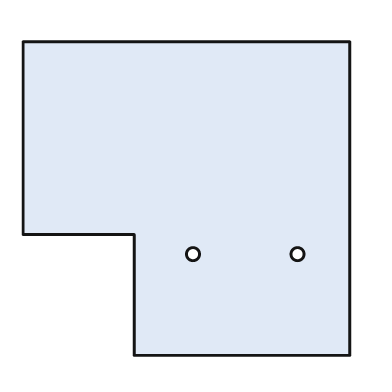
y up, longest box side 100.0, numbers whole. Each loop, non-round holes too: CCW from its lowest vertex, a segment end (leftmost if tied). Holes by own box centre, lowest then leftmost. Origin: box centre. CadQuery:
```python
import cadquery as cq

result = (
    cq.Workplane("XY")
    .moveTo(-16.0, -48.0)
    .lineTo(50.0, -48.0)
    .lineTo(50.0, 48.0)
    .lineTo(-50.0, 48.0)
    .lineTo(-50.0, -11.0)
    .lineTo(-16.0, -11.0)
    .close()
    .moveTo(2.0, -17.0)
    .circle(2.0)
    .moveTo(34.0, -17.0)
    .circle(2.0)
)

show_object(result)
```